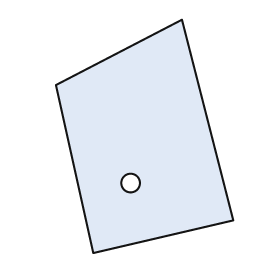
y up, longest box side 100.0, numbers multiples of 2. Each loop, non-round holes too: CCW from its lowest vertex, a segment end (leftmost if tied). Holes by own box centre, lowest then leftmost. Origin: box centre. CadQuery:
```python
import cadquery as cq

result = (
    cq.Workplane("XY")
    .moveTo(-22.0, -50.0)
    .lineTo(38.0, -36.0)
    .lineTo(16.0, 50.0)
    .lineTo(-38.0, 22.0)
    .close()
    .moveTo(-6.0, -20.0)
    .circle(4.0)
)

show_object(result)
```